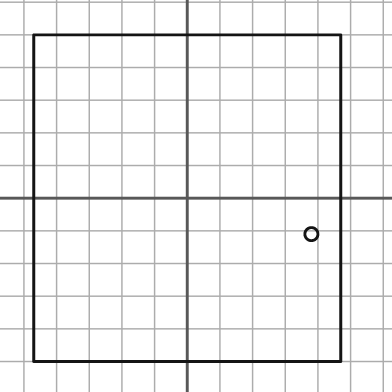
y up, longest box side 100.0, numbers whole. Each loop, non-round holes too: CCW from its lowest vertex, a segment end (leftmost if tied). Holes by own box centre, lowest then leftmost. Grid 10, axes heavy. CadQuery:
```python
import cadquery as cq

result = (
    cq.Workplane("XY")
    .moveTo(-47.0, -50.0)
    .lineTo(47.0, -50.0)
    .lineTo(47.0, 50.0)
    .lineTo(-47.0, 50.0)
    .close()
    .moveTo(38.0, -11.0)
    .circle(2.0)
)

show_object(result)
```